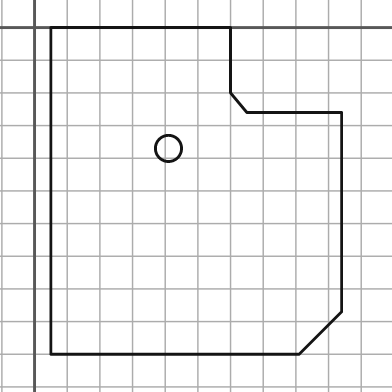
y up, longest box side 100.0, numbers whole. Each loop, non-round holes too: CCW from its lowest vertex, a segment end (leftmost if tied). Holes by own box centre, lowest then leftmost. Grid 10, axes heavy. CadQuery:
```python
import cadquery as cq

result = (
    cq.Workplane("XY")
    .moveTo(5.0, -100.0)
    .lineTo(81.0, -100.0)
    .lineTo(94.0, -87.0)
    .lineTo(94.0, -26.0)
    .lineTo(65.0, -26.0)
    .lineTo(60.0, -20.0)
    .lineTo(60.0, 0.0)
    .lineTo(5.0, 0.0)
    .close()
    .moveTo(41.0, -37.0)
    .circle(4.0)
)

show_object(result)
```